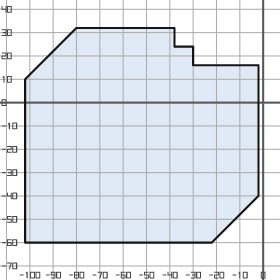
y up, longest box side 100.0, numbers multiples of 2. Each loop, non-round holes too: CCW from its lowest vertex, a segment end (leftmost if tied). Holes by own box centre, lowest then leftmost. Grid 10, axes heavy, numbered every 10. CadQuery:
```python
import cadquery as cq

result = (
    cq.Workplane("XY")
    .moveTo(-102.0, -60.0)
    .lineTo(-22.0, -60.0)
    .lineTo(-2.0, -40.0)
    .lineTo(-2.0, 16.0)
    .lineTo(-30.0, 16.0)
    .lineTo(-30.0, 24.0)
    .lineTo(-38.0, 24.0)
    .lineTo(-38.0, 32.0)
    .lineTo(-80.0, 32.0)
    .lineTo(-102.0, 10.0)
    .close()
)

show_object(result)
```